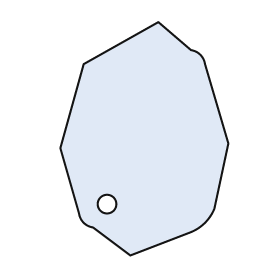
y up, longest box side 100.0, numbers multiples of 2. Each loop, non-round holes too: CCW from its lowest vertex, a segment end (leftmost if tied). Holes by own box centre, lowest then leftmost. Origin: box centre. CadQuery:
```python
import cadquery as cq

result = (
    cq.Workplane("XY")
    .moveTo(-6.0, -50.0)
    .lineTo(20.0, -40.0)
    .threePointArc((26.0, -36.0), (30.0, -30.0))
    .lineTo(36.0, -2.0)
    .lineTo(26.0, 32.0)
    .threePointArc((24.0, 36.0), (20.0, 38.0))
    .lineTo(6.0, 50.0)
    .lineTo(-26.0, 32.0)
    .lineTo(-36.0, -4.0)
    .lineTo(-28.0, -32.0)
    .threePointArc((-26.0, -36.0), (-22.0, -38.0))
    .close()
    .moveTo(-16.0, -28.0)
    .circle(4.0)
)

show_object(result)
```